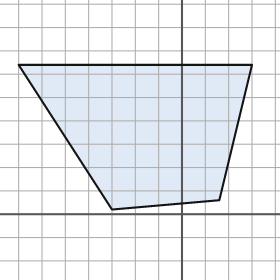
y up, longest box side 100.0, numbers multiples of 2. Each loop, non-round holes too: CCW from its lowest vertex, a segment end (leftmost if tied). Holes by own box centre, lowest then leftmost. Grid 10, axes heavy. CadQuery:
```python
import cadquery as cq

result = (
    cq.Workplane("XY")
    .moveTo(-30.0, 2.0)
    .lineTo(16.0, 6.0)
    .lineTo(30.0, 64.0)
    .lineTo(-70.0, 64.0)
    .close()
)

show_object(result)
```